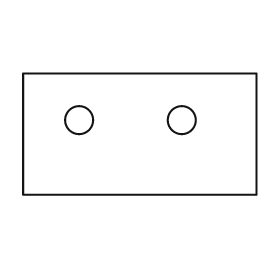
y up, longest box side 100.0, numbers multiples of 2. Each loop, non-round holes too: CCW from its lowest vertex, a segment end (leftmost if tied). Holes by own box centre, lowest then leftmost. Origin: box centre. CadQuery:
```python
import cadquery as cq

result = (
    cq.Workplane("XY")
    .moveTo(-50.0, -26.0)
    .lineTo(50.0, -26.0)
    .lineTo(50.0, 26.0)
    .lineTo(-50.0, 26.0)
    .close()
    .moveTo(-26.0, 6.0)
    .circle(6.0)
    .moveTo(18.0, 6.0)
    .circle(6.0)
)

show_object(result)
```